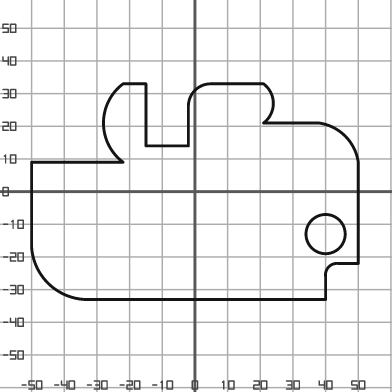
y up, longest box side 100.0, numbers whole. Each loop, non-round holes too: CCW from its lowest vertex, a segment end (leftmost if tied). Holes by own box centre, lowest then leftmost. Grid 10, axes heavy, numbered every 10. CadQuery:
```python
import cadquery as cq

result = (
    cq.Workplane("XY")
    .moveTo(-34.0, -33.0)
    .lineTo(40.0, -33.0)
    .lineTo(40.0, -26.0)
    .threePointArc((41.0, -23.0), (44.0, -22.0))
    .lineTo(50.0, -22.0)
    .lineTo(50.0, 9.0)
    .threePointArc((46.0, 17.0), (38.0, 21.0))
    .lineTo(21.0, 21.0)
    .threePointArc((24.0, 27.0), (21.0, 33.0))
    .lineTo(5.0, 33.0)
    .threePointArc((0.0, 31.0), (-2.0, 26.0))
    .lineTo(-2.0, 14.0)
    .lineTo(-15.0, 14.0)
    .lineTo(-15.0, 33.0)
    .lineTo(-22.0, 33.0)
    .threePointArc((-28.0, 21.0), (-22.0, 9.0))
    .lineTo(-50.0, 9.0)
    .lineTo(-50.0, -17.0)
    .threePointArc((-45.0, -28.0), (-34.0, -33.0))
    .close()
    .moveTo(40.0, -13.0)
    .circle(6.0)
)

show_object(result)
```